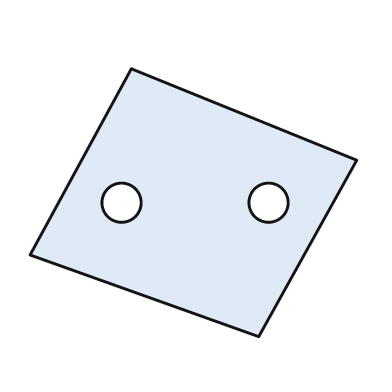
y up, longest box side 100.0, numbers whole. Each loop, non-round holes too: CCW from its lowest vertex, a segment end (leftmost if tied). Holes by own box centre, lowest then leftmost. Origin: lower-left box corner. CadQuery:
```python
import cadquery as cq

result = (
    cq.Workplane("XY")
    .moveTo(70.0, 0.0)
    .lineTo(100.0, 54.0)
    .lineTo(31.0, 82.0)
    .lineTo(0.0, 25.0)
    .close()
    .moveTo(28.0, 41.0)
    .circle(6.0)
    .moveTo(73.0, 41.0)
    .circle(6.0)
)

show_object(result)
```